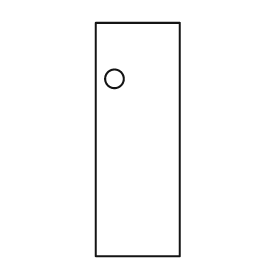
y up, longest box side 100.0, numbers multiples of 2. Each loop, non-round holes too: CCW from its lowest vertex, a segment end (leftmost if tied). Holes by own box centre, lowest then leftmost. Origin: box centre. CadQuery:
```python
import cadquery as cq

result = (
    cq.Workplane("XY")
    .moveTo(-18.0, -50.0)
    .lineTo(18.0, -50.0)
    .lineTo(18.0, 50.0)
    .lineTo(-18.0, 50.0)
    .close()
    .moveTo(-10.0, 26.0)
    .circle(4.0)
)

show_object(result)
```